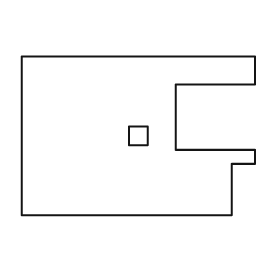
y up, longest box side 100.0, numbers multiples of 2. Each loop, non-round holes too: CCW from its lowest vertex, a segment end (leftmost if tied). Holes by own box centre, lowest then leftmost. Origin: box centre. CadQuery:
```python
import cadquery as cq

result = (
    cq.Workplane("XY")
    .moveTo(-50.0, -34.0)
    .lineTo(40.0, -34.0)
    .lineTo(40.0, -12.0)
    .lineTo(50.0, -12.0)
    .lineTo(50.0, -6.0)
    .lineTo(16.0, -6.0)
    .lineTo(16.0, 22.0)
    .lineTo(50.0, 22.0)
    .lineTo(50.0, 34.0)
    .lineTo(-50.0, 34.0)
    .close()
    .moveTo(-4.0, -4.0)
    .lineTo(4.0, -4.0)
    .lineTo(4.0, 4.0)
    .lineTo(-4.0, 4.0)
    .close()
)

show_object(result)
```